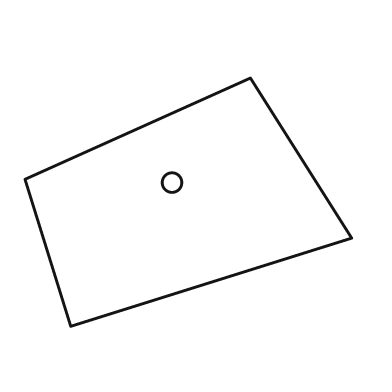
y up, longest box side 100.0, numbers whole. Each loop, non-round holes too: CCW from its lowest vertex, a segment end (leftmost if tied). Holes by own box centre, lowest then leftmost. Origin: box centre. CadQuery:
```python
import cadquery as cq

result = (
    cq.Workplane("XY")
    .moveTo(-36.0, -38.0)
    .lineTo(50.0, -11.0)
    .lineTo(19.0, 38.0)
    .lineTo(-50.0, 7.0)
    .close()
    .moveTo(-5.0, 6.0)
    .circle(3.0)
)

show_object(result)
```